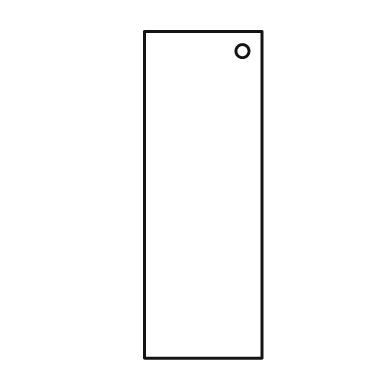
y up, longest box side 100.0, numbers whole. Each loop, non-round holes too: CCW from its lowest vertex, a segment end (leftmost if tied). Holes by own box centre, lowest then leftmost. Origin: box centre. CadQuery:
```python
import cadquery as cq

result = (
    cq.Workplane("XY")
    .moveTo(-18.0, -50.0)
    .lineTo(18.0, -50.0)
    .lineTo(18.0, 50.0)
    .lineTo(-18.0, 50.0)
    .close()
    .moveTo(12.0, 44.0)
    .circle(2.0)
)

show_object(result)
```